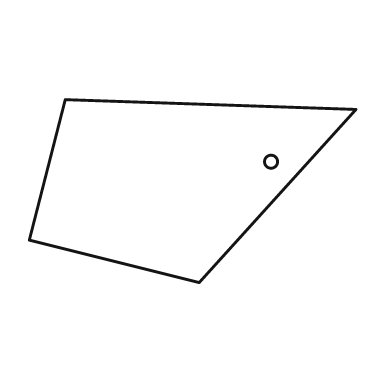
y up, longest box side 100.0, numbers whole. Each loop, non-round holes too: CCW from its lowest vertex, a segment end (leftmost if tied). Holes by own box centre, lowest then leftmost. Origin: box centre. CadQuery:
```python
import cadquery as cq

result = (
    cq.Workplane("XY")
    .moveTo(2.0, -28.0)
    .lineTo(50.0, 25.0)
    .lineTo(-39.0, 28.0)
    .lineTo(-50.0, -15.0)
    .close()
    .moveTo(24.0, 9.0)
    .circle(2.0)
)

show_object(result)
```